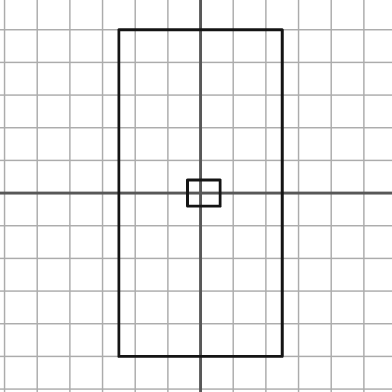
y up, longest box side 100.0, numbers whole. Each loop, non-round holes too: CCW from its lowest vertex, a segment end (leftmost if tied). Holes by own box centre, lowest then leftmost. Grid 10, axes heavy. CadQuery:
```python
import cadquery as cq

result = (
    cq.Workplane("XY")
    .moveTo(-25.0, -50.0)
    .lineTo(25.0, -50.0)
    .lineTo(25.0, 50.0)
    .lineTo(-25.0, 50.0)
    .close()
    .moveTo(-4.0, -4.0)
    .lineTo(6.0, -4.0)
    .lineTo(6.0, 4.0)
    .lineTo(-4.0, 4.0)
    .close()
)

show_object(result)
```